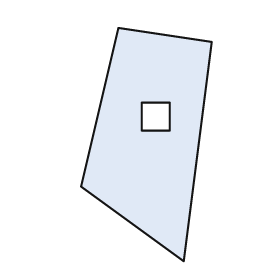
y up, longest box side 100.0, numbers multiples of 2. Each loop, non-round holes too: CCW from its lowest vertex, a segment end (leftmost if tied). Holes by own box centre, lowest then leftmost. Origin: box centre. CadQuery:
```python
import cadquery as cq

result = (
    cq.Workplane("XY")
    .moveTo(16.0, -50.0)
    .lineTo(28.0, 44.0)
    .lineTo(-12.0, 50.0)
    .lineTo(-28.0, -18.0)
    .close()
    .moveTo(-2.0, 6.0)
    .lineTo(10.0, 6.0)
    .lineTo(10.0, 18.0)
    .lineTo(-2.0, 18.0)
    .close()
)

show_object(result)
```